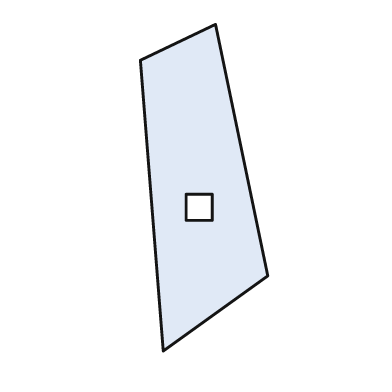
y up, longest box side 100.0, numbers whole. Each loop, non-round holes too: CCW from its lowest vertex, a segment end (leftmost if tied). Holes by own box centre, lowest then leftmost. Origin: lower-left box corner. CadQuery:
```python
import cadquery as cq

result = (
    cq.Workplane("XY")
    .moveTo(7.0, 0.0)
    .lineTo(39.0, 23.0)
    .lineTo(23.0, 100.0)
    .lineTo(0.0, 89.0)
    .close()
    .moveTo(14.0, 40.0)
    .lineTo(22.0, 40.0)
    .lineTo(22.0, 48.0)
    .lineTo(14.0, 48.0)
    .close()
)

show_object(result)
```